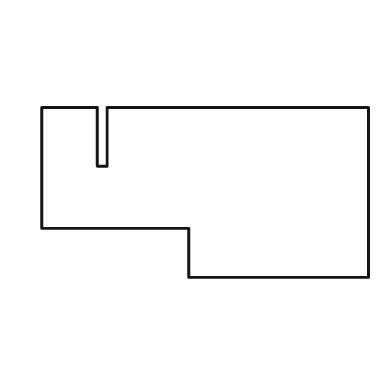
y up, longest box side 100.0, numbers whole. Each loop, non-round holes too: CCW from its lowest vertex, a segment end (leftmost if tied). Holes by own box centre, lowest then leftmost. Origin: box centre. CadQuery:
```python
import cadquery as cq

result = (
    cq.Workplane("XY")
    .moveTo(-5.0, -26.0)
    .lineTo(50.0, -26.0)
    .lineTo(50.0, 26.0)
    .lineTo(-30.0, 26.0)
    .lineTo(-30.0, 8.0)
    .lineTo(-33.0, 8.0)
    .lineTo(-33.0, 26.0)
    .lineTo(-50.0, 26.0)
    .lineTo(-50.0, -11.0)
    .lineTo(-5.0, -11.0)
    .close()
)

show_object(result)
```